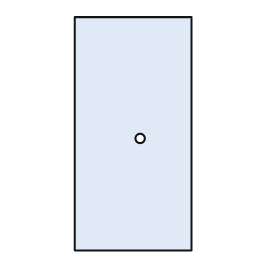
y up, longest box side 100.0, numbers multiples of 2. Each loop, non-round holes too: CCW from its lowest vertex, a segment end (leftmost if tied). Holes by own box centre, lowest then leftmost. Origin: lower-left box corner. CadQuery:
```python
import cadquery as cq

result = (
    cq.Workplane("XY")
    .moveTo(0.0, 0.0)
    .lineTo(50.0, 0.0)
    .lineTo(50.0, 100.0)
    .lineTo(0.0, 100.0)
    .close()
    .moveTo(28.0, 48.0)
    .circle(2.0)
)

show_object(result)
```